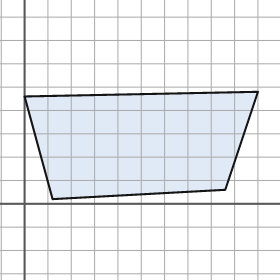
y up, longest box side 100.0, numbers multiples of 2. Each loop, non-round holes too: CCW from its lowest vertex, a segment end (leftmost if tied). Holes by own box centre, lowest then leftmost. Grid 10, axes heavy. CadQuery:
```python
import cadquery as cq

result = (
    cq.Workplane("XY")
    .moveTo(12.0, 2.0)
    .lineTo(86.0, 6.0)
    .lineTo(100.0, 48.0)
    .lineTo(0.0, 46.0)
    .close()
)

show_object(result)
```